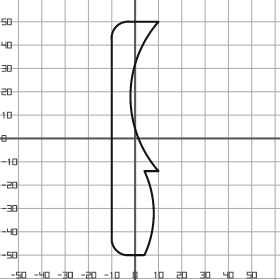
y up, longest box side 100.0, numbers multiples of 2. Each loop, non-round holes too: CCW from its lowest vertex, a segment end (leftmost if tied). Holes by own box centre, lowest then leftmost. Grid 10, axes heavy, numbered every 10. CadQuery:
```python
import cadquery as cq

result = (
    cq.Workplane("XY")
    .moveTo(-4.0, -50.0)
    .lineTo(4.0, -50.0)
    .threePointArc((8.0, -32.0), (4.0, -14.0))
    .lineTo(10.0, -14.0)
    .threePointArc((-2.0, 18.0), (10.0, 50.0))
    .lineTo(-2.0, 50.0)
    .threePointArc((-8.0, 48.0), (-10.0, 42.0))
    .lineTo(-10.0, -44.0)
    .threePointArc((-8.0, -48.0), (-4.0, -50.0))
    .close()
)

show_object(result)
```